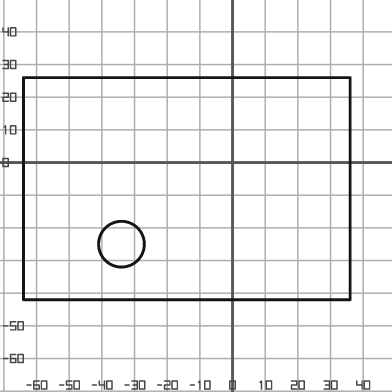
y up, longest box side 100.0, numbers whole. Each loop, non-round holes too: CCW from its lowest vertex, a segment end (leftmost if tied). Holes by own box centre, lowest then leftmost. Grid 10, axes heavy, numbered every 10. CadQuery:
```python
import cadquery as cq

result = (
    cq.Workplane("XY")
    .moveTo(-64.0, -42.0)
    .lineTo(36.0, -42.0)
    .lineTo(36.0, 26.0)
    .lineTo(-64.0, 26.0)
    .close()
    .moveTo(-34.0, -25.0)
    .circle(7.0)
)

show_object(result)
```